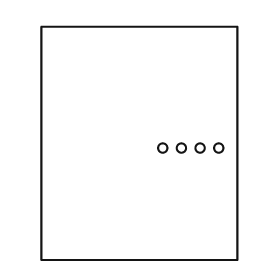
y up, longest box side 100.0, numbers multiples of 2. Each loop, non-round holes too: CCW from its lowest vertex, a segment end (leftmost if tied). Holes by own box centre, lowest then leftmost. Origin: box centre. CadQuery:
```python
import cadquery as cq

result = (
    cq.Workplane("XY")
    .moveTo(-42.0, -50.0)
    .lineTo(42.0, -50.0)
    .lineTo(42.0, 50.0)
    .lineTo(-42.0, 50.0)
    .close()
    .moveTo(10.0, -2.0)
    .circle(2.0)
    .moveTo(18.0, -2.0)
    .circle(2.0)
    .moveTo(26.0, -2.0)
    .circle(2.0)
    .moveTo(34.0, -2.0)
    .circle(2.0)
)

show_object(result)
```